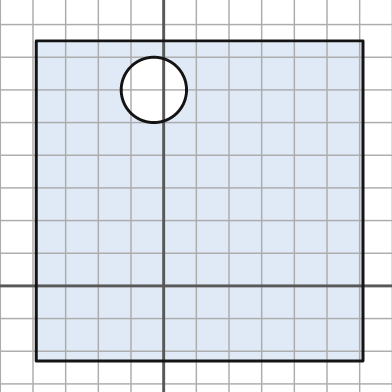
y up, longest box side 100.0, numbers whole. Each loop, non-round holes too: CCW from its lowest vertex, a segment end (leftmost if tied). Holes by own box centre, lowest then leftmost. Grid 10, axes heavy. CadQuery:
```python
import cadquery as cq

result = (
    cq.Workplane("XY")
    .moveTo(-39.0, -23.0)
    .lineTo(61.0, -23.0)
    .lineTo(61.0, 75.0)
    .lineTo(-39.0, 75.0)
    .close()
    .moveTo(-3.0, 60.0)
    .circle(10.0)
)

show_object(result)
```